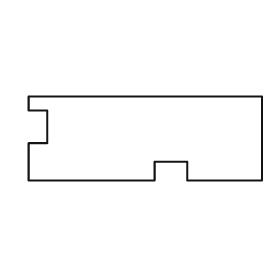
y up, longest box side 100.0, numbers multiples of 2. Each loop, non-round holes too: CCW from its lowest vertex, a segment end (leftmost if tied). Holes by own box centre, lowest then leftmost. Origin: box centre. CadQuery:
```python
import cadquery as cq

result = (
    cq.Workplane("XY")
    .moveTo(-50.0, -18.0)
    .lineTo(4.0, -18.0)
    .lineTo(4.0, -10.0)
    .lineTo(18.0, -10.0)
    .lineTo(18.0, -18.0)
    .lineTo(50.0, -18.0)
    .lineTo(50.0, 18.0)
    .lineTo(-50.0, 18.0)
    .lineTo(-50.0, 12.0)
    .lineTo(-42.0, 12.0)
    .lineTo(-42.0, -2.0)
    .lineTo(-50.0, -2.0)
    .close()
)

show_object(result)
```